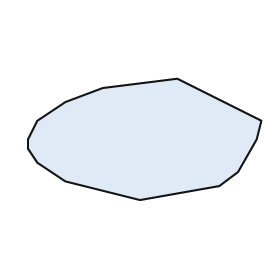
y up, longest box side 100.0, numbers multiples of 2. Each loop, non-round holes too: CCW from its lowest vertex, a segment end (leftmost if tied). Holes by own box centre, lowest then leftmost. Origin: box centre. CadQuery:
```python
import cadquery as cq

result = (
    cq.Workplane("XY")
    .moveTo(-2.0, -26.0)
    .lineTo(32.0, -20.0)
    .lineTo(40.0, -14.0)
    .lineTo(48.0, 0.0)
    .lineTo(50.0, 8.0)
    .lineTo(14.0, 26.0)
    .lineTo(-18.0, 22.0)
    .lineTo(-34.0, 16.0)
    .lineTo(-46.0, 8.0)
    .lineTo(-50.0, 0.0)
    .lineTo(-50.0, -4.0)
    .lineTo(-46.0, -10.0)
    .lineTo(-34.0, -18.0)
    .close()
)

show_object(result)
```